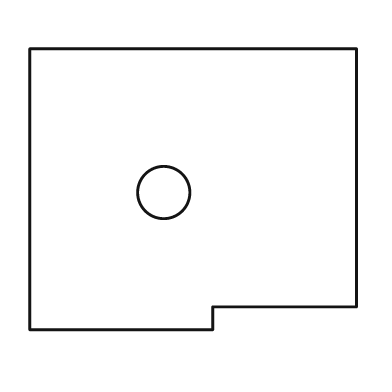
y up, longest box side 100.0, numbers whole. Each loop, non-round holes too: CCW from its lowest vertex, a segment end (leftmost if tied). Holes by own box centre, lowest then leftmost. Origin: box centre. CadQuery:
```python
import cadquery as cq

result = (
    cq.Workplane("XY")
    .moveTo(-50.0, -43.0)
    .lineTo(6.0, -43.0)
    .lineTo(6.0, -36.0)
    .lineTo(50.0, -36.0)
    .lineTo(50.0, 43.0)
    .lineTo(-50.0, 43.0)
    .close()
    .moveTo(-9.0, -1.0)
    .circle(8.0)
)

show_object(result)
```